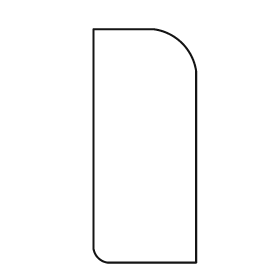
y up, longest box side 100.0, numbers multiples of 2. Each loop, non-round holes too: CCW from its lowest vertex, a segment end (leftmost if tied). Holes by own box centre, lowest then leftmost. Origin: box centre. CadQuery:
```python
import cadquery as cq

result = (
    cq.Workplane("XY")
    .moveTo(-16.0, -50.0)
    .lineTo(22.0, -50.0)
    .lineTo(22.0, 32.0)
    .threePointArc((16.0, 44.0), (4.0, 50.0))
    .lineTo(-22.0, 50.0)
    .lineTo(-22.0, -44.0)
    .threePointArc((-20.0, -48.0), (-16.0, -50.0))
    .close()
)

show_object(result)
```